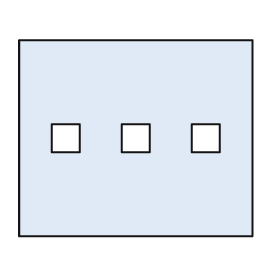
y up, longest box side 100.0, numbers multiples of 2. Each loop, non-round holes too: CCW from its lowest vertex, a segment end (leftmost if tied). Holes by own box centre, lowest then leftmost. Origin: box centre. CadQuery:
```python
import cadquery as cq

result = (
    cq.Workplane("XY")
    .moveTo(-50.0, -42.0)
    .lineTo(50.0, -42.0)
    .lineTo(50.0, 42.0)
    .lineTo(-50.0, 42.0)
    .close()
    .moveTo(-36.0, -6.0)
    .lineTo(-24.0, -6.0)
    .lineTo(-24.0, 6.0)
    .lineTo(-36.0, 6.0)
    .close()
    .moveTo(-6.0, -6.0)
    .lineTo(6.0, -6.0)
    .lineTo(6.0, 6.0)
    .lineTo(-6.0, 6.0)
    .close()
    .moveTo(24.0, -6.0)
    .lineTo(36.0, -6.0)
    .lineTo(36.0, 6.0)
    .lineTo(24.0, 6.0)
    .close()
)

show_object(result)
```